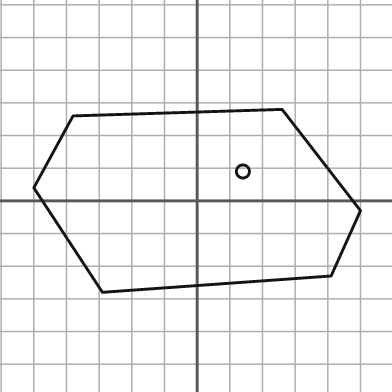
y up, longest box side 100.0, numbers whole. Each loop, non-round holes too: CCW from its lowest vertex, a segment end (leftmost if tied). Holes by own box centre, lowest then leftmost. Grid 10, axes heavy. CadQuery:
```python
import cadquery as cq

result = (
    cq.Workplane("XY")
    .moveTo(-29.0, -28.0)
    .lineTo(41.0, -23.0)
    .lineTo(50.0, -3.0)
    .lineTo(26.0, 28.0)
    .lineTo(-38.0, 26.0)
    .lineTo(-50.0, 4.0)
    .close()
    .moveTo(14.0, 9.0)
    .circle(2.0)
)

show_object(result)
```